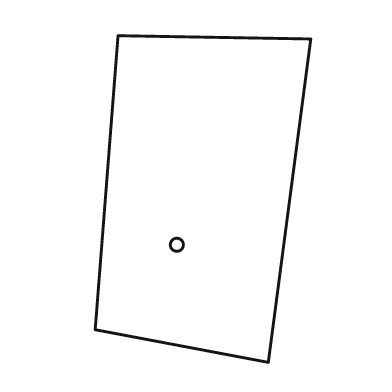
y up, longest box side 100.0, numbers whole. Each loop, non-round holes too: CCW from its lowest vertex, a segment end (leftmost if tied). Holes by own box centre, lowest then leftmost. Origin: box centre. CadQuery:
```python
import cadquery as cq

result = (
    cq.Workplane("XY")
    .moveTo(20.0, -50.0)
    .lineTo(33.0, 49.0)
    .lineTo(-26.0, 50.0)
    .lineTo(-33.0, -40.0)
    .close()
    .moveTo(-8.0, -14.0)
    .circle(2.0)
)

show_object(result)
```